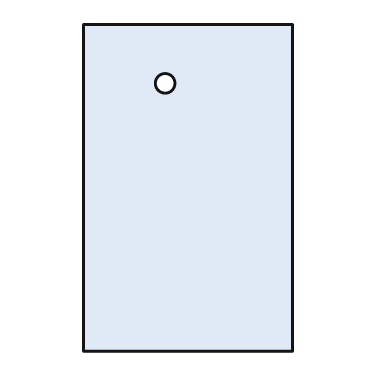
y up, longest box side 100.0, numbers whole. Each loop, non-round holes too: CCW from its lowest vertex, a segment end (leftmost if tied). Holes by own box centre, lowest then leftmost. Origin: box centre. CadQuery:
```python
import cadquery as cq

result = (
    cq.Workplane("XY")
    .moveTo(-32.0, -50.0)
    .lineTo(32.0, -50.0)
    .lineTo(32.0, 50.0)
    .lineTo(-32.0, 50.0)
    .close()
    .moveTo(-7.0, 32.0)
    .circle(3.0)
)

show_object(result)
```